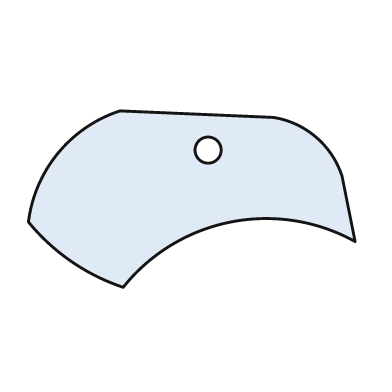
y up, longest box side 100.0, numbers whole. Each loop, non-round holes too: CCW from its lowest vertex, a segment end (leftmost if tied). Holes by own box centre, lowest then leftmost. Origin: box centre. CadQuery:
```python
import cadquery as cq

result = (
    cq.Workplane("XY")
    .moveTo(-21.0, -27.0)
    .threePointArc((12.0, -7.0), (50.0, -13.0))
    .lineTo(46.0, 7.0)
    .threePointArc((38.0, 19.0), (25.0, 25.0))
    .lineTo(-22.0, 27.0)
    .threePointArc((-41.0, 14.0), (-50.0, -7.0))
    .threePointArc((-37.0, -19.0), (-21.0, -27.0))
    .close()
    .moveTo(5.0, 15.0)
    .circle(4.0)
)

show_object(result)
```